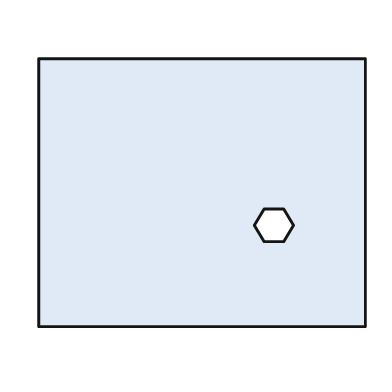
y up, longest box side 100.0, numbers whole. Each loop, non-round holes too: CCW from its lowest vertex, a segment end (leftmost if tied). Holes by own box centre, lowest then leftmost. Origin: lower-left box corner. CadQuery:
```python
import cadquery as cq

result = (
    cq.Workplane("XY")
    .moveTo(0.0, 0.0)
    .lineTo(100.0, 0.0)
    .lineTo(100.0, 82.0)
    .lineTo(0.0, 82.0)
    .close()
    .moveTo(69.0, 26.0)
    .lineTo(75.0, 26.0)
    .lineTo(78.0, 31.0)
    .lineTo(75.0, 36.0)
    .lineTo(69.0, 36.0)
    .lineTo(66.0, 31.0)
    .close()
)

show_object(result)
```